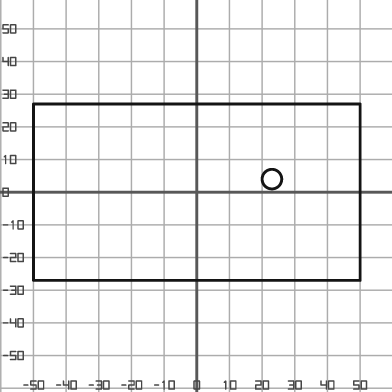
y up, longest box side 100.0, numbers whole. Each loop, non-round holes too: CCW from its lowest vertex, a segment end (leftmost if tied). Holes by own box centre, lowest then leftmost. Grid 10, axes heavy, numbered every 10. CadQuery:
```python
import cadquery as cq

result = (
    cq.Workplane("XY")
    .moveTo(-50.0, -27.0)
    .lineTo(50.0, -27.0)
    .lineTo(50.0, 27.0)
    .lineTo(-50.0, 27.0)
    .close()
    .moveTo(23.0, 4.0)
    .circle(3.0)
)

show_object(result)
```